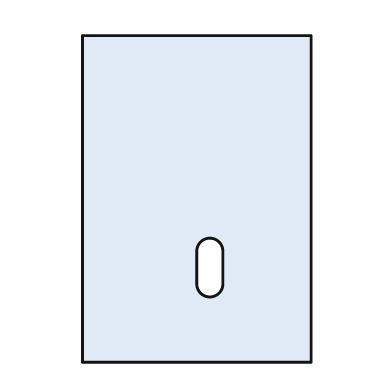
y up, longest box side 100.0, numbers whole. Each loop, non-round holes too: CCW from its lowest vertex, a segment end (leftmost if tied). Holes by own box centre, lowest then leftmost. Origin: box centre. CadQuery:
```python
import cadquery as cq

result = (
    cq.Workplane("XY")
    .moveTo(-35.0, -50.0)
    .lineTo(35.0, -50.0)
    .lineTo(35.0, 50.0)
    .lineTo(-35.0, 50.0)
    .close()
    .moveTo(0.0, -26.0)
    .threePointArc((4.0, -30.0), (8.0, -26.0))
    .lineTo(8.0, -16.0)
    .threePointArc((4.0, -12.0), (0.0, -16.0))
    .close()
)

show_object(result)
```